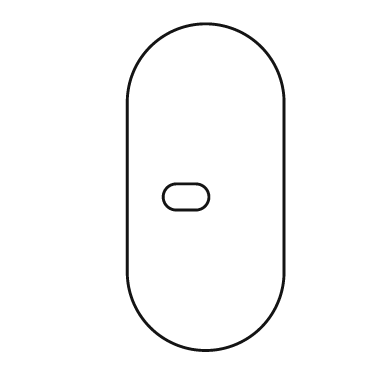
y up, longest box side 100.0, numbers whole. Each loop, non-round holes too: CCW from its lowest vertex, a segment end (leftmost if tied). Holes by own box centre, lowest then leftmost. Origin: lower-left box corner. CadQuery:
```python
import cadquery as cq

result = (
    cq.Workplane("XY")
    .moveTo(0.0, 24.0)
    .threePointArc((24.0, 0.0), (48.0, 24.0))
    .lineTo(48.0, 76.0)
    .threePointArc((24.0, 100.0), (0.0, 76.0))
    .close()
    .moveTo(15.0, 43.0)
    .lineTo(21.0, 43.0)
    .threePointArc((25.0, 47.0), (21.0, 51.0))
    .lineTo(15.0, 51.0)
    .threePointArc((11.0, 47.0), (15.0, 43.0))
    .close()
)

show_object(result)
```